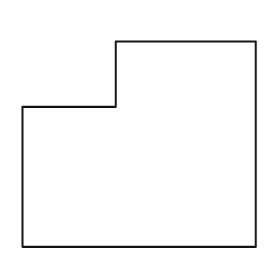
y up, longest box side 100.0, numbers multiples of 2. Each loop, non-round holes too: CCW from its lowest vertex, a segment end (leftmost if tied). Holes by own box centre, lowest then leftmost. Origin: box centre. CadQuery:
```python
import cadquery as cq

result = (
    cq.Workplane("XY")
    .moveTo(-50.0, -44.0)
    .lineTo(50.0, -44.0)
    .lineTo(50.0, 44.0)
    .lineTo(-10.0, 44.0)
    .lineTo(-10.0, 16.0)
    .lineTo(-50.0, 16.0)
    .close()
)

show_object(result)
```